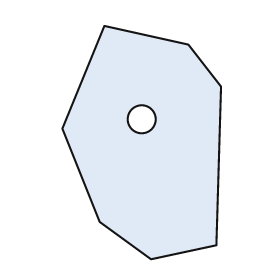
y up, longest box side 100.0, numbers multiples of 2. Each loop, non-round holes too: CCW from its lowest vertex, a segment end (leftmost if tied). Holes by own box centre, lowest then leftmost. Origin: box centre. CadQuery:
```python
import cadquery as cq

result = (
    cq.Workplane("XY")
    .moveTo(4.0, -50.0)
    .lineTo(32.0, -44.0)
    .lineTo(34.0, 24.0)
    .lineTo(20.0, 42.0)
    .lineTo(-16.0, 50.0)
    .lineTo(-34.0, 6.0)
    .lineTo(-18.0, -34.0)
    .close()
    .moveTo(0.0, 10.0)
    .circle(6.0)
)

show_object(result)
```